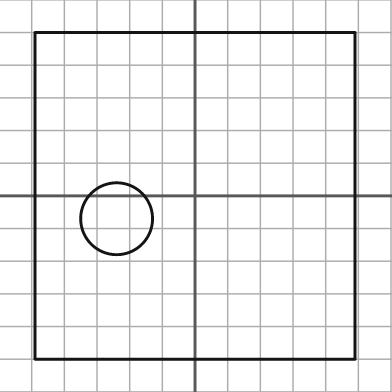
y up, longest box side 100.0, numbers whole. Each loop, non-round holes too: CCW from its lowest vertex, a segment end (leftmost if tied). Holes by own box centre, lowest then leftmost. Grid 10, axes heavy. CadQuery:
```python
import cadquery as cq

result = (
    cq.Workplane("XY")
    .moveTo(-49.0, -50.0)
    .lineTo(49.0, -50.0)
    .lineTo(49.0, 50.0)
    .lineTo(-49.0, 50.0)
    .close()
    .moveTo(-24.0, -7.0)
    .circle(11.0)
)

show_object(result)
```